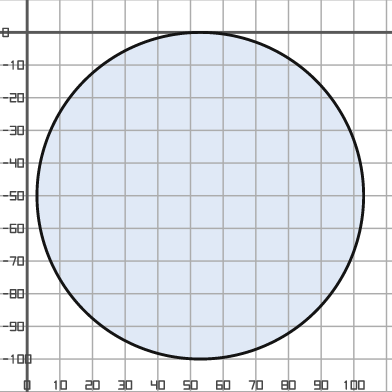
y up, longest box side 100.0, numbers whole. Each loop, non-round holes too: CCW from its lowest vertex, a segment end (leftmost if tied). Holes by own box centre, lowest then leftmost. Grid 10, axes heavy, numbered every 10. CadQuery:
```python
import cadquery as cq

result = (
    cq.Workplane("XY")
    .moveTo(53.0, -50.0)
    .circle(50.0)
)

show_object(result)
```